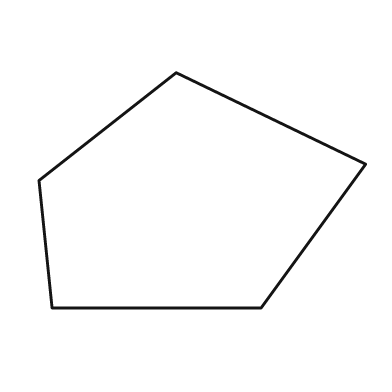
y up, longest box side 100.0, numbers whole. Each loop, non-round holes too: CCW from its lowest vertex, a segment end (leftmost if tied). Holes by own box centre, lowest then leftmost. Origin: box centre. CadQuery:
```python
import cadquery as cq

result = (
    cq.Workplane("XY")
    .moveTo(-46.0, -36.0)
    .lineTo(18.0, -36.0)
    .lineTo(50.0, 8.0)
    .lineTo(-8.0, 36.0)
    .lineTo(-50.0, 3.0)
    .close()
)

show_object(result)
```